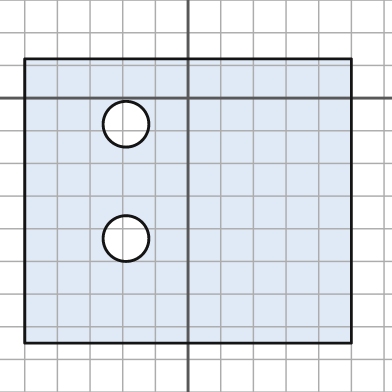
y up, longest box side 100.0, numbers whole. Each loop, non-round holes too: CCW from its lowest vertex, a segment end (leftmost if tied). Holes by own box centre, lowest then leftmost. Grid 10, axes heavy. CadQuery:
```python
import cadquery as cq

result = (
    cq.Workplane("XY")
    .moveTo(-50.0, -75.0)
    .lineTo(50.0, -75.0)
    .lineTo(50.0, 12.0)
    .lineTo(-50.0, 12.0)
    .close()
    .moveTo(-19.0, -43.0)
    .circle(7.0)
    .moveTo(-19.0, -8.0)
    .circle(7.0)
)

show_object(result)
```